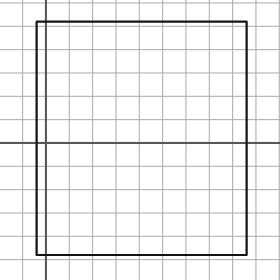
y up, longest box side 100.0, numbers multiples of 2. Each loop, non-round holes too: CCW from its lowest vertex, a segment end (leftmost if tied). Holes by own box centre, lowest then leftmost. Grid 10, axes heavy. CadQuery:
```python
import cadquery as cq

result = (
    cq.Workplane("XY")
    .moveTo(-4.0, -48.0)
    .lineTo(86.0, -48.0)
    .lineTo(86.0, 52.0)
    .lineTo(-4.0, 52.0)
    .close()
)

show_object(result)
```